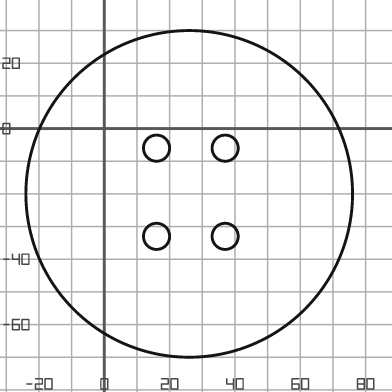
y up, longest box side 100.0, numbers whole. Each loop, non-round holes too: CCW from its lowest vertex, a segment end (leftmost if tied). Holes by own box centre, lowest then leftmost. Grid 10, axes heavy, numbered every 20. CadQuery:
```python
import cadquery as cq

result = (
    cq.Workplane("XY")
    .moveTo(26.0, -20.0)
    .circle(50.0)
    .moveTo(16.0, -33.0)
    .circle(4.0)
    .moveTo(37.0, -33.0)
    .circle(4.0)
    .moveTo(16.0, -6.0)
    .circle(4.0)
    .moveTo(37.0, -6.0)
    .circle(4.0)
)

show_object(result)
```